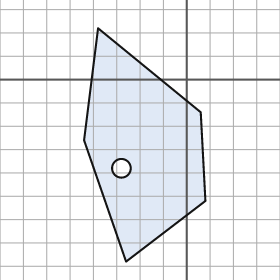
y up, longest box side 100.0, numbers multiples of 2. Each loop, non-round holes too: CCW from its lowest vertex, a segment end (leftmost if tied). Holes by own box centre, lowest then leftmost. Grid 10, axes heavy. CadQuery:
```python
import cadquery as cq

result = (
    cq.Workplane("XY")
    .moveTo(-26.0, -78.0)
    .lineTo(8.0, -52.0)
    .lineTo(6.0, -14.0)
    .lineTo(-38.0, 22.0)
    .lineTo(-44.0, -26.0)
    .close()
    .moveTo(-28.0, -38.0)
    .circle(4.0)
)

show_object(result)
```